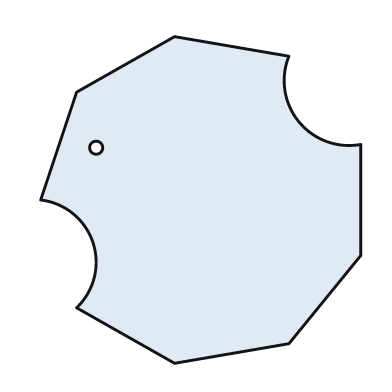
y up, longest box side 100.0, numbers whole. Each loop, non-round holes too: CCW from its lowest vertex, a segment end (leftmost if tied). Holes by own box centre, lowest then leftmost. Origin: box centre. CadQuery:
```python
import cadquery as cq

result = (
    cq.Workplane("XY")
    .moveTo(-8.0, -50.0)
    .lineTo(27.0, -44.0)
    .lineTo(49.0, -17.0)
    .lineTo(49.0, 17.0)
    .threePointArc((30.0, 24.0), (27.0, 44.0))
    .lineTo(-8.0, 50.0)
    .lineTo(-38.0, 33.0)
    .lineTo(-49.0, 0.0)
    .threePointArc((-33.0, -13.0), (-38.0, -33.0))
    .close()
    .moveTo(-32.0, 16.0)
    .circle(2.0)
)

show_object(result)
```